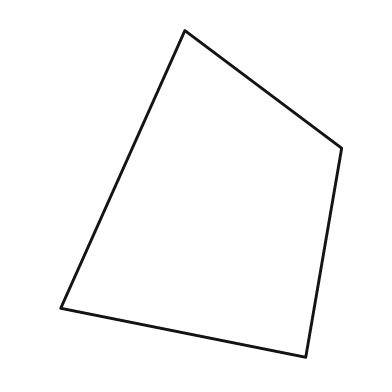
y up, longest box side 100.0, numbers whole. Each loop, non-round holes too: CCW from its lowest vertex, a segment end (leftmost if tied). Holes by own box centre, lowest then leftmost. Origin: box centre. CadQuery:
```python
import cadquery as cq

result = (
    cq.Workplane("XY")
    .moveTo(32.0, -50.0)
    .lineTo(43.0, 14.0)
    .lineTo(-5.0, 50.0)
    .lineTo(-43.0, -35.0)
    .close()
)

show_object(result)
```